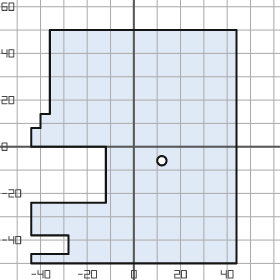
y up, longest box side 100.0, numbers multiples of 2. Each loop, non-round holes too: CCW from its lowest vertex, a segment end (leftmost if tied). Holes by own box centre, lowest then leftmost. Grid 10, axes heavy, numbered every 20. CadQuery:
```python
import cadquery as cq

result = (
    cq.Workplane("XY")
    .moveTo(-44.0, -50.0)
    .lineTo(44.0, -50.0)
    .lineTo(44.0, 50.0)
    .lineTo(-36.0, 50.0)
    .lineTo(-36.0, 14.0)
    .lineTo(-40.0, 14.0)
    .lineTo(-40.0, 8.0)
    .lineTo(-44.0, 8.0)
    .lineTo(-44.0, 0.0)
    .lineTo(-12.0, 0.0)
    .lineTo(-12.0, -24.0)
    .lineTo(-44.0, -24.0)
    .lineTo(-44.0, -38.0)
    .lineTo(-28.0, -38.0)
    .lineTo(-28.0, -46.0)
    .lineTo(-44.0, -46.0)
    .close()
    .moveTo(12.0, -6.0)
    .circle(2.0)
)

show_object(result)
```